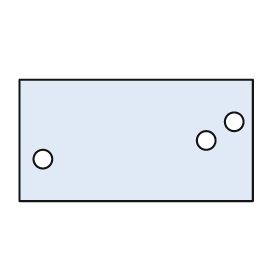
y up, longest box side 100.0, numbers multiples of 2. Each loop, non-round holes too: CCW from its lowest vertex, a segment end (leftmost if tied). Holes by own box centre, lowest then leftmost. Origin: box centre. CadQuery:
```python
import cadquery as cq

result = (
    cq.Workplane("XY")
    .moveTo(-50.0, -26.0)
    .lineTo(50.0, -26.0)
    .lineTo(50.0, 26.0)
    .lineTo(-50.0, 26.0)
    .close()
    .moveTo(-40.0, -8.0)
    .circle(4.0)
    .moveTo(30.0, 0.0)
    .circle(4.0)
    .moveTo(42.0, 8.0)
    .circle(4.0)
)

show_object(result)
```